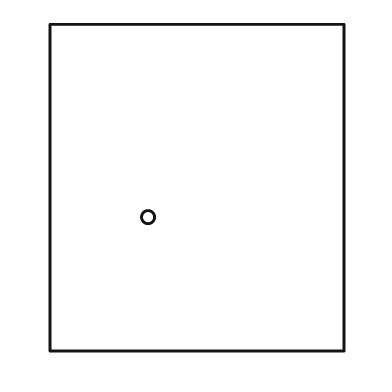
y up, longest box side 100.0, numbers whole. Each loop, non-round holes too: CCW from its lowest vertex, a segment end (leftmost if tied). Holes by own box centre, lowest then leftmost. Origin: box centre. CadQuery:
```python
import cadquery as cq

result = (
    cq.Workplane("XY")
    .moveTo(-45.0, -50.0)
    .lineTo(45.0, -50.0)
    .lineTo(45.0, 50.0)
    .lineTo(-45.0, 50.0)
    .close()
    .moveTo(-15.0, -9.0)
    .circle(2.0)
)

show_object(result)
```